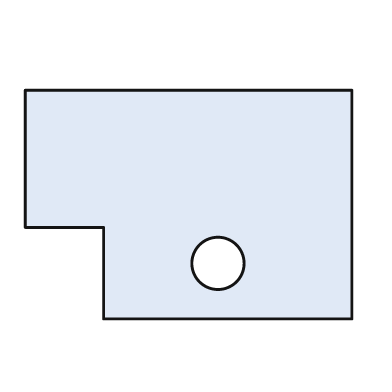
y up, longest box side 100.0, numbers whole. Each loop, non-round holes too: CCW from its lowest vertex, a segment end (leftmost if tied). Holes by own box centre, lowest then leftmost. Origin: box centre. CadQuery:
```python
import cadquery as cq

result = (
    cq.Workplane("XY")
    .moveTo(-26.0, -35.0)
    .lineTo(50.0, -35.0)
    .lineTo(50.0, 35.0)
    .lineTo(-50.0, 35.0)
    .lineTo(-50.0, -7.0)
    .lineTo(-26.0, -7.0)
    .close()
    .moveTo(9.0, -18.0)
    .circle(8.0)
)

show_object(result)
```